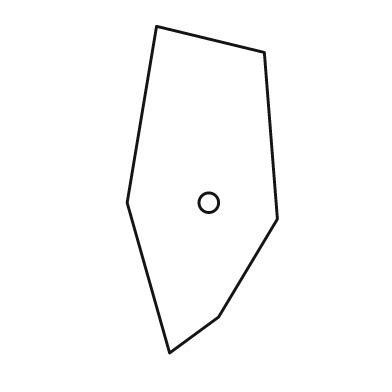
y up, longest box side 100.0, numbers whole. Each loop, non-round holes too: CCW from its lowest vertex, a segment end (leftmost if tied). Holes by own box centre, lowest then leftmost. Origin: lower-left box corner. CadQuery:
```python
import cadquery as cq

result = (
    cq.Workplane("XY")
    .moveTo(13.0, 0.0)
    .lineTo(28.0, 11.0)
    .lineTo(46.0, 41.0)
    .lineTo(42.0, 92.0)
    .lineTo(9.0, 100.0)
    .lineTo(0.0, 46.0)
    .close()
    .moveTo(25.0, 46.0)
    .circle(3.0)
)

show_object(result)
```